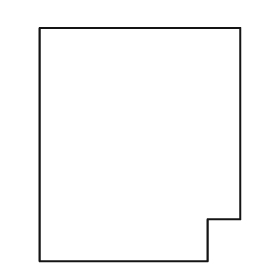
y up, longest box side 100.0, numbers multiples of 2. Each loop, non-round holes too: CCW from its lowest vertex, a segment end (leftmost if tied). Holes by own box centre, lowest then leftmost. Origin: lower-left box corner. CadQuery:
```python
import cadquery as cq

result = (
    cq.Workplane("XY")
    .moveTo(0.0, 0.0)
    .lineTo(72.0, 0.0)
    .lineTo(72.0, 18.0)
    .lineTo(86.0, 18.0)
    .lineTo(86.0, 100.0)
    .lineTo(0.0, 100.0)
    .close()
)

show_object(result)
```